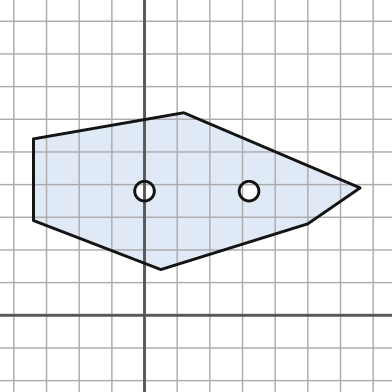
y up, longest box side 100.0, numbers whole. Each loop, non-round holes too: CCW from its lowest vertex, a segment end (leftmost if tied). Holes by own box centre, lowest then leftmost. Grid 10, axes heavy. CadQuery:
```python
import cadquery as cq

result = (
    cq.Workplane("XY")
    .moveTo(5.0, 14.0)
    .lineTo(50.0, 28.0)
    .lineTo(66.0, 39.0)
    .lineTo(12.0, 62.0)
    .lineTo(-34.0, 54.0)
    .lineTo(-34.0, 29.0)
    .close()
    .moveTo(0.0, 38.0)
    .circle(3.0)
    .moveTo(32.0, 38.0)
    .circle(3.0)
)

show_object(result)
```